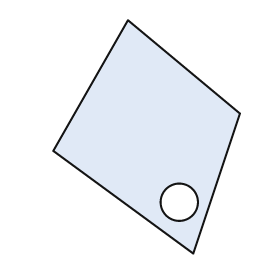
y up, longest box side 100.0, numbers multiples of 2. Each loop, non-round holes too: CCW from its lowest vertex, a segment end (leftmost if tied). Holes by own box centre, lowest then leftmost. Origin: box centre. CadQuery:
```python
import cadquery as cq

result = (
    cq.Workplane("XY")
    .moveTo(20.0, -50.0)
    .lineTo(40.0, 10.0)
    .lineTo(-8.0, 50.0)
    .lineTo(-40.0, -6.0)
    .close()
    .moveTo(14.0, -28.0)
    .circle(8.0)
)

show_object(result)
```